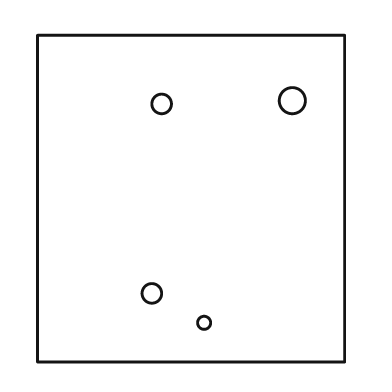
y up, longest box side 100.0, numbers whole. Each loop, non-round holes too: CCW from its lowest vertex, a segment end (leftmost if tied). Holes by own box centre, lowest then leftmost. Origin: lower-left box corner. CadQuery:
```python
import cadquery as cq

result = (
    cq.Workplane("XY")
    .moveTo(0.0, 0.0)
    .lineTo(94.0, 0.0)
    .lineTo(94.0, 100.0)
    .lineTo(0.0, 100.0)
    .close()
    .moveTo(51.0, 12.0)
    .circle(2.0)
    .moveTo(35.0, 21.0)
    .circle(3.0)
    .moveTo(38.0, 79.0)
    .circle(3.0)
    .moveTo(78.0, 80.0)
    .circle(4.0)
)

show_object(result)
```